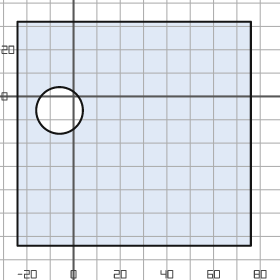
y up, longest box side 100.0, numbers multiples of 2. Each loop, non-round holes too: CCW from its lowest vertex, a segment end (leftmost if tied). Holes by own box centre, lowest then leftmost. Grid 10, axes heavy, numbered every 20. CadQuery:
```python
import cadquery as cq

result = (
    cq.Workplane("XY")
    .moveTo(-24.0, -64.0)
    .lineTo(76.0, -64.0)
    .lineTo(76.0, 32.0)
    .lineTo(-24.0, 32.0)
    .close()
    .moveTo(-6.0, -6.0)
    .circle(10.0)
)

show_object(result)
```